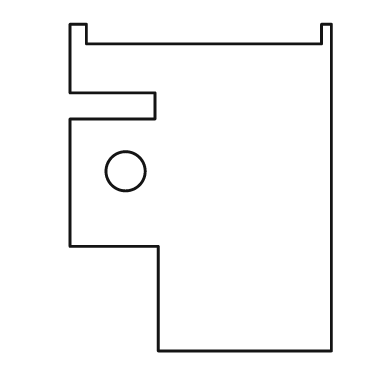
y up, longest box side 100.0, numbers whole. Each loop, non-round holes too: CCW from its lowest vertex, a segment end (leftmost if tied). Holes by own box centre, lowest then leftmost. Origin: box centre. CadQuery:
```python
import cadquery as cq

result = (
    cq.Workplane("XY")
    .moveTo(-13.0, -50.0)
    .lineTo(40.0, -50.0)
    .lineTo(40.0, 50.0)
    .lineTo(37.0, 50.0)
    .lineTo(37.0, 44.0)
    .lineTo(-35.0, 44.0)
    .lineTo(-35.0, 50.0)
    .lineTo(-40.0, 50.0)
    .lineTo(-40.0, 29.0)
    .lineTo(-14.0, 29.0)
    .lineTo(-14.0, 21.0)
    .lineTo(-40.0, 21.0)
    .lineTo(-40.0, -18.0)
    .lineTo(-13.0, -18.0)
    .close()
    .moveTo(-23.0, 5.0)
    .circle(6.0)
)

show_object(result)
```